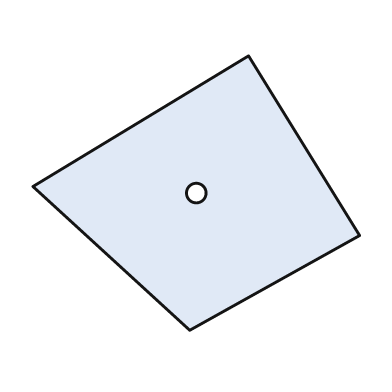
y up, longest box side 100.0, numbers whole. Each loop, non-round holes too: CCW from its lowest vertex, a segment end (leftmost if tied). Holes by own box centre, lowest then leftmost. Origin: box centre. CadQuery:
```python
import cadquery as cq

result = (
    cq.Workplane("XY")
    .moveTo(-2.0, -42.0)
    .lineTo(50.0, -13.0)
    .lineTo(16.0, 42.0)
    .lineTo(-50.0, 2.0)
    .close()
    .moveTo(0.0, 0.0)
    .circle(3.0)
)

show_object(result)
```